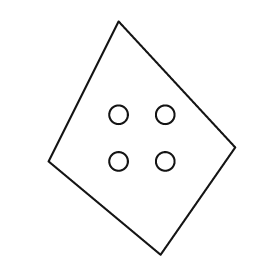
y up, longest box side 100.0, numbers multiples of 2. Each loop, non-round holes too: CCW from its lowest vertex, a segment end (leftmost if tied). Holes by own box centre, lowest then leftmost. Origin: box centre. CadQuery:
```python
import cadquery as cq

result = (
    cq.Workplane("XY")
    .moveTo(8.0, -50.0)
    .lineTo(40.0, -4.0)
    .lineTo(-10.0, 50.0)
    .lineTo(-40.0, -10.0)
    .close()
    .moveTo(-10.0, -10.0)
    .circle(4.0)
    .moveTo(10.0, -10.0)
    .circle(4.0)
    .moveTo(-10.0, 10.0)
    .circle(4.0)
    .moveTo(10.0, 10.0)
    .circle(4.0)
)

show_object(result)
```